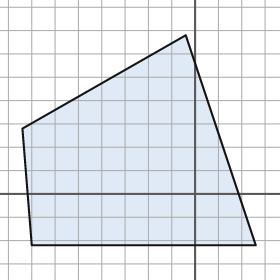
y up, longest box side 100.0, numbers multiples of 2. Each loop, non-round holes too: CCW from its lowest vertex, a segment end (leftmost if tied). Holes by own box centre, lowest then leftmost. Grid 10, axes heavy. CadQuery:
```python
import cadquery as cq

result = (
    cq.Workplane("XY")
    .moveTo(-70.0, -22.0)
    .lineTo(26.0, -22.0)
    .lineTo(-4.0, 68.0)
    .lineTo(-74.0, 28.0)
    .close()
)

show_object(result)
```